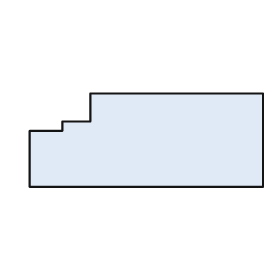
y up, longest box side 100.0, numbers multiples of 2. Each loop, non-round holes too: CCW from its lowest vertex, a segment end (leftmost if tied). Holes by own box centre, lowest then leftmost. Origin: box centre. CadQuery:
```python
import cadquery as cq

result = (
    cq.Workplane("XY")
    .moveTo(-50.0, -20.0)
    .lineTo(50.0, -20.0)
    .lineTo(50.0, 20.0)
    .lineTo(-24.0, 20.0)
    .lineTo(-24.0, 8.0)
    .lineTo(-36.0, 8.0)
    .lineTo(-36.0, 4.0)
    .lineTo(-50.0, 4.0)
    .close()
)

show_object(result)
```